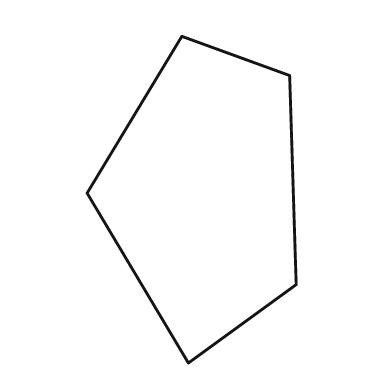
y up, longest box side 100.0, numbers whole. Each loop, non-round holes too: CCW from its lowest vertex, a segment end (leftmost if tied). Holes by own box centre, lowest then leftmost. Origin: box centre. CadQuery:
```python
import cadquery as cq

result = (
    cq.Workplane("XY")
    .moveTo(-1.0, -50.0)
    .lineTo(32.0, -26.0)
    .lineTo(30.0, 38.0)
    .lineTo(-3.0, 50.0)
    .lineTo(-32.0, 2.0)
    .close()
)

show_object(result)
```